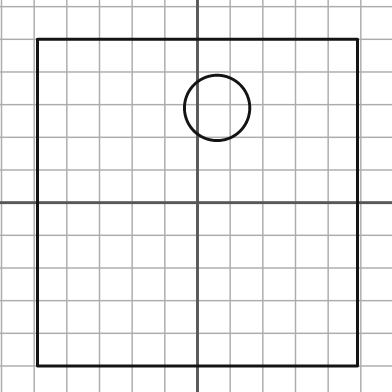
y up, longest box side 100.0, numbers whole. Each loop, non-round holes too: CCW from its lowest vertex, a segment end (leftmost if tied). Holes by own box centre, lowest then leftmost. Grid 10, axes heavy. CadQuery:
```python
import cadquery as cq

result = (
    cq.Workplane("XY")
    .moveTo(-49.0, -50.0)
    .lineTo(49.0, -50.0)
    .lineTo(49.0, 50.0)
    .lineTo(-49.0, 50.0)
    .close()
    .moveTo(6.0, 29.0)
    .circle(10.0)
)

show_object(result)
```